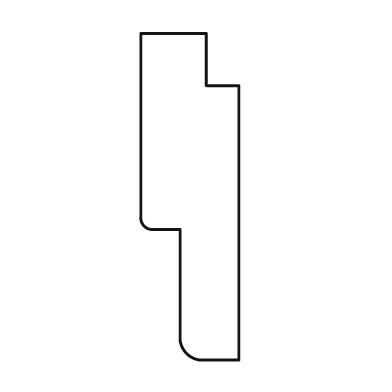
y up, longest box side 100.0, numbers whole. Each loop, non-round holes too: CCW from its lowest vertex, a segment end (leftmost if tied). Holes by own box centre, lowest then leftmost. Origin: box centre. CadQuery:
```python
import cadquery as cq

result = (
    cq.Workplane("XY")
    .moveTo(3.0, -50.0)
    .lineTo(15.0, -50.0)
    .lineTo(15.0, 34.0)
    .lineTo(5.0, 34.0)
    .lineTo(5.0, 50.0)
    .lineTo(-15.0, 50.0)
    .lineTo(-15.0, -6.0)
    .threePointArc((-14.0, -9.0), (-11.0, -10.0))
    .lineTo(-3.0, -10.0)
    .lineTo(-3.0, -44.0)
    .threePointArc((-1.0, -48.0), (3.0, -50.0))
    .close()
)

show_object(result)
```